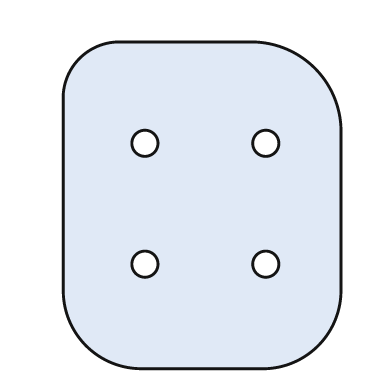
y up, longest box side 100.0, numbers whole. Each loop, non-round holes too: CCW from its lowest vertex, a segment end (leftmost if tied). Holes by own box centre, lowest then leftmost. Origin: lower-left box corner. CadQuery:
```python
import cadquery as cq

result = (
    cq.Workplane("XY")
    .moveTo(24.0, 0.0)
    .lineTo(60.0, 0.0)
    .threePointArc((78.0, 7.0), (85.0, 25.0))
    .lineTo(85.0, 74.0)
    .threePointArc((77.0, 92.0), (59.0, 100.0))
    .lineTo(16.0, 100.0)
    .threePointArc((5.0, 95.0), (0.0, 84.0))
    .lineTo(0.0, 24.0)
    .threePointArc((7.0, 7.0), (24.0, 0.0))
    .close()
    .moveTo(25.0, 32.0)
    .circle(4.0)
    .moveTo(62.0, 32.0)
    .circle(4.0)
    .moveTo(25.0, 69.0)
    .circle(4.0)
    .moveTo(62.0, 69.0)
    .circle(4.0)
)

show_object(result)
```